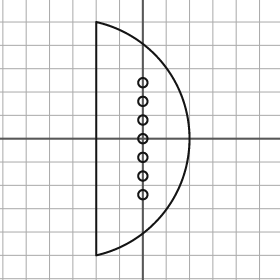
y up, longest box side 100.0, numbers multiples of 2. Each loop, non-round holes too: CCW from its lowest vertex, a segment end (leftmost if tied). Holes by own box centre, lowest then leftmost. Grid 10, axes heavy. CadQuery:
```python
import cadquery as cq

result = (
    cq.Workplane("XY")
    .moveTo(-20.0, -50.0)
    .threePointArc((20.0, 0.0), (-20.0, 50.0))
    .close()
    .moveTo(0.0, -24.0)
    .circle(2.0)
    .moveTo(0.0, -16.0)
    .circle(2.0)
    .moveTo(0.0, -8.0)
    .circle(2.0)
    .moveTo(0.0, 0.0)
    .circle(2.0)
    .moveTo(0.0, 8.0)
    .circle(2.0)
    .moveTo(0.0, 16.0)
    .circle(2.0)
    .moveTo(0.0, 24.0)
    .circle(2.0)
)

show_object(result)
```